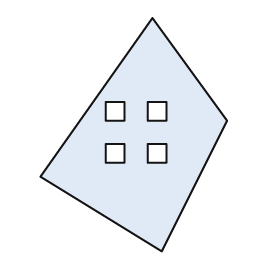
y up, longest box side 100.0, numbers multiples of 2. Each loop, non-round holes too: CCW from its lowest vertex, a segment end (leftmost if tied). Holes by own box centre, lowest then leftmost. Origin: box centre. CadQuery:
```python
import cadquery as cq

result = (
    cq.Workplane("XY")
    .moveTo(12.0, -50.0)
    .lineTo(40.0, 6.0)
    .lineTo(8.0, 50.0)
    .lineTo(-40.0, -18.0)
    .close()
    .moveTo(-12.0, -12.0)
    .lineTo(-4.0, -12.0)
    .lineTo(-4.0, -4.0)
    .lineTo(-12.0, -4.0)
    .close()
    .moveTo(6.0, -12.0)
    .lineTo(14.0, -12.0)
    .lineTo(14.0, -4.0)
    .lineTo(6.0, -4.0)
    .close()
    .moveTo(-12.0, 6.0)
    .lineTo(-4.0, 6.0)
    .lineTo(-4.0, 14.0)
    .lineTo(-12.0, 14.0)
    .close()
    .moveTo(6.0, 6.0)
    .lineTo(14.0, 6.0)
    .lineTo(14.0, 14.0)
    .lineTo(6.0, 14.0)
    .close()
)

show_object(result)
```